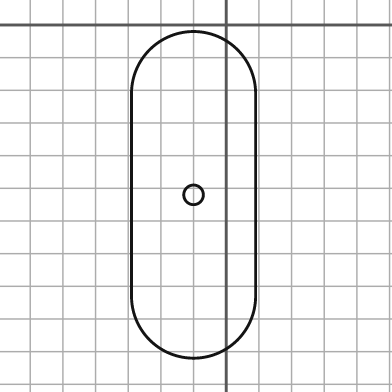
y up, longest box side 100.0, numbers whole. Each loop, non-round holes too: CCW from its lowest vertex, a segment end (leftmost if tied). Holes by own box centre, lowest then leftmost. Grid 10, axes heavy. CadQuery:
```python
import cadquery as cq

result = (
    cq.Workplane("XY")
    .moveTo(-29.0, -83.0)
    .threePointArc((-10.0, -102.0), (9.0, -83.0))
    .lineTo(9.0, -21.0)
    .threePointArc((-10.0, -2.0), (-29.0, -21.0))
    .close()
    .moveTo(-10.0, -52.0)
    .circle(3.0)
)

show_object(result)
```